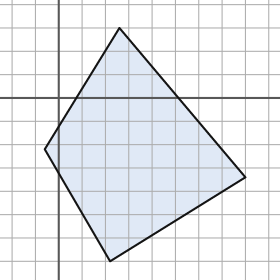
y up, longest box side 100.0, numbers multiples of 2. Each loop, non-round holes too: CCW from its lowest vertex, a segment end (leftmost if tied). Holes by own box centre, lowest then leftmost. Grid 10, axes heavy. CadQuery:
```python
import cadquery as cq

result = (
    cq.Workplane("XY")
    .moveTo(22.0, -70.0)
    .lineTo(80.0, -34.0)
    .lineTo(26.0, 30.0)
    .lineTo(-6.0, -22.0)
    .close()
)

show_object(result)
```